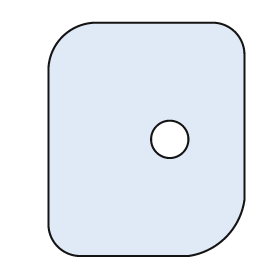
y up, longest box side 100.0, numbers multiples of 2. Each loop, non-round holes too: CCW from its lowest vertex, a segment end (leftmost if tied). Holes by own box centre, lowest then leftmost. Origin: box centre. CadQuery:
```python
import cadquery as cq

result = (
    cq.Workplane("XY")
    .moveTo(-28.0, -50.0)
    .lineTo(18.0, -50.0)
    .threePointArc((34.0, -42.0), (42.0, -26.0))
    .lineTo(42.0, 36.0)
    .threePointArc((38.0, 46.0), (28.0, 50.0))
    .lineTo(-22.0, 50.0)
    .threePointArc((-36.0, 44.0), (-42.0, 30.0))
    .lineTo(-42.0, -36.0)
    .threePointArc((-38.0, -46.0), (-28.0, -50.0))
    .close()
    .moveTo(10.0, 0.0)
    .circle(8.0)
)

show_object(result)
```